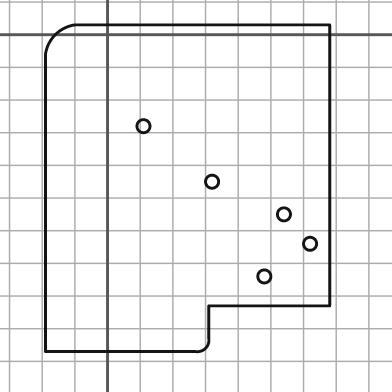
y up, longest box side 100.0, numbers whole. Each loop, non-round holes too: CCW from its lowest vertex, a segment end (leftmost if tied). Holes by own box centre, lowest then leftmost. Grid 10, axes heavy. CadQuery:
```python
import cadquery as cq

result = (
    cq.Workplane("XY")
    .moveTo(-19.0, -97.0)
    .lineTo(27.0, -97.0)
    .threePointArc((30.0, -96.0), (31.0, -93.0))
    .lineTo(31.0, -83.0)
    .lineTo(68.0, -83.0)
    .lineTo(68.0, 3.0)
    .lineTo(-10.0, 3.0)
    .threePointArc((-16.0, 0.0), (-19.0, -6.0))
    .close()
    .moveTo(48.0, -74.0)
    .circle(2.0)
    .moveTo(62.0, -64.0)
    .circle(2.0)
    .moveTo(54.0, -55.0)
    .circle(2.0)
    .moveTo(32.0, -45.0)
    .circle(2.0)
    .moveTo(11.0, -28.0)
    .circle(2.0)
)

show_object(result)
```